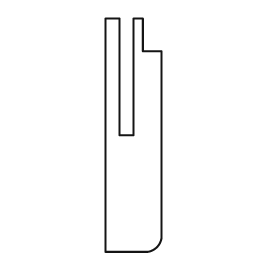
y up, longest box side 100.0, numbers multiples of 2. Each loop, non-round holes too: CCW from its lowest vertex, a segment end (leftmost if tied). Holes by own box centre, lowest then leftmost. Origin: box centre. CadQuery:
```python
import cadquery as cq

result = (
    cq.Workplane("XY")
    .moveTo(-12.0, -50.0)
    .lineTo(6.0, -50.0)
    .threePointArc((10.0, -48.0), (12.0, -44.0))
    .lineTo(12.0, 36.0)
    .lineTo(4.0, 36.0)
    .lineTo(4.0, 50.0)
    .lineTo(0.0, 50.0)
    .lineTo(0.0, 0.0)
    .lineTo(-6.0, 0.0)
    .lineTo(-6.0, 50.0)
    .lineTo(-12.0, 50.0)
    .close()
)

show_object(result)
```